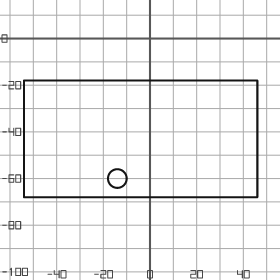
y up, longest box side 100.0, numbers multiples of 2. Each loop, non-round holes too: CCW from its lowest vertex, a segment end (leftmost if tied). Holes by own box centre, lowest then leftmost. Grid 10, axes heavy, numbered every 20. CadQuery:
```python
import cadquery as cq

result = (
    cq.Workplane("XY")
    .moveTo(-54.0, -68.0)
    .lineTo(46.0, -68.0)
    .lineTo(46.0, -18.0)
    .lineTo(-54.0, -18.0)
    .close()
    .moveTo(-14.0, -60.0)
    .circle(4.0)
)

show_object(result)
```